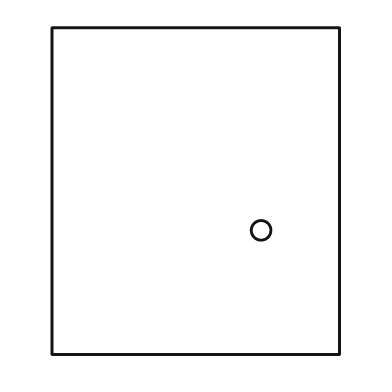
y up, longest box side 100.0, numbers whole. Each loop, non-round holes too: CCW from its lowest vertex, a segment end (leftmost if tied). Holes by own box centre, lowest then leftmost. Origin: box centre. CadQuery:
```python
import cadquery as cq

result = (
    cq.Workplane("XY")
    .moveTo(-44.0, -50.0)
    .lineTo(44.0, -50.0)
    .lineTo(44.0, 50.0)
    .lineTo(-44.0, 50.0)
    .close()
    .moveTo(20.0, -12.0)
    .circle(3.0)
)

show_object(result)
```